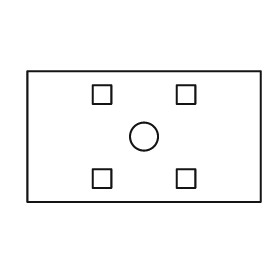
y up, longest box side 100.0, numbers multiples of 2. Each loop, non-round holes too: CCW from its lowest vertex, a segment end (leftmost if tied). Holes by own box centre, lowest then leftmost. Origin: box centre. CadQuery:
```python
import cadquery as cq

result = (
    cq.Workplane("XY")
    .moveTo(-50.0, -28.0)
    .lineTo(50.0, -28.0)
    .lineTo(50.0, 28.0)
    .lineTo(-50.0, 28.0)
    .close()
    .moveTo(-22.0, -22.0)
    .lineTo(-14.0, -22.0)
    .lineTo(-14.0, -14.0)
    .lineTo(-22.0, -14.0)
    .close()
    .moveTo(14.0, -22.0)
    .lineTo(22.0, -22.0)
    .lineTo(22.0, -14.0)
    .lineTo(14.0, -14.0)
    .close()
    .moveTo(0.0, 0.0)
    .circle(6.0)
    .moveTo(-22.0, 14.0)
    .lineTo(-14.0, 14.0)
    .lineTo(-14.0, 22.0)
    .lineTo(-22.0, 22.0)
    .close()
    .moveTo(14.0, 14.0)
    .lineTo(22.0, 14.0)
    .lineTo(22.0, 22.0)
    .lineTo(14.0, 22.0)
    .close()
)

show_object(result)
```